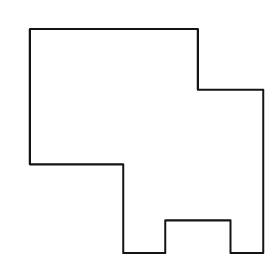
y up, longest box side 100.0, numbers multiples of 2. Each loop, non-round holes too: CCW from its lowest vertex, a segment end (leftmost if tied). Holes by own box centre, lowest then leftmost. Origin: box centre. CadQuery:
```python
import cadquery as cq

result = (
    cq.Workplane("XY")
    .moveTo(-10.0, -48.0)
    .lineTo(8.0, -48.0)
    .lineTo(8.0, -34.0)
    .lineTo(36.0, -34.0)
    .lineTo(36.0, -48.0)
    .lineTo(50.0, -48.0)
    .lineTo(50.0, 22.0)
    .lineTo(22.0, 22.0)
    .lineTo(22.0, 48.0)
    .lineTo(-50.0, 48.0)
    .lineTo(-50.0, -10.0)
    .lineTo(-10.0, -10.0)
    .close()
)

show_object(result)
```